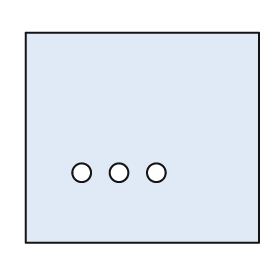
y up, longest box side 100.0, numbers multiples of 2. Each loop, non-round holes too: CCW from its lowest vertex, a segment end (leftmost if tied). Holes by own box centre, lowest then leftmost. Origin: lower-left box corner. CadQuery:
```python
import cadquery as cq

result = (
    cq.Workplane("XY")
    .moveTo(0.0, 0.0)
    .lineTo(100.0, 0.0)
    .lineTo(100.0, 90.0)
    .lineTo(0.0, 90.0)
    .close()
    .moveTo(24.0, 30.0)
    .circle(4.0)
    .moveTo(40.0, 30.0)
    .circle(4.0)
    .moveTo(56.0, 30.0)
    .circle(4.0)
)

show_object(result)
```